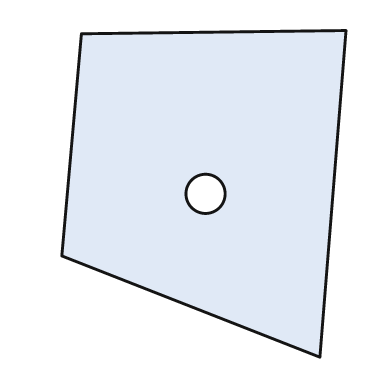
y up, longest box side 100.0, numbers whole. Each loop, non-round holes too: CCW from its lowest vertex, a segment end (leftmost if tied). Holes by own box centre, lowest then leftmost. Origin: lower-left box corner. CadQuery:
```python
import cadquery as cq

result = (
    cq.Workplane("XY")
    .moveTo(79.0, 0.0)
    .lineTo(87.0, 100.0)
    .lineTo(6.0, 99.0)
    .lineTo(0.0, 31.0)
    .close()
    .moveTo(44.0, 50.0)
    .circle(6.0)
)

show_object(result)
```